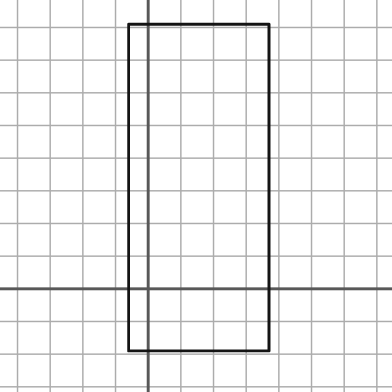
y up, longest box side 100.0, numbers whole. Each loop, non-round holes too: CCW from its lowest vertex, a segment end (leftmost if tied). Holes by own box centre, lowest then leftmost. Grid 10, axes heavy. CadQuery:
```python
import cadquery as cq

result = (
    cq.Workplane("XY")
    .moveTo(-6.0, -19.0)
    .lineTo(37.0, -19.0)
    .lineTo(37.0, 81.0)
    .lineTo(-6.0, 81.0)
    .close()
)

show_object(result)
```